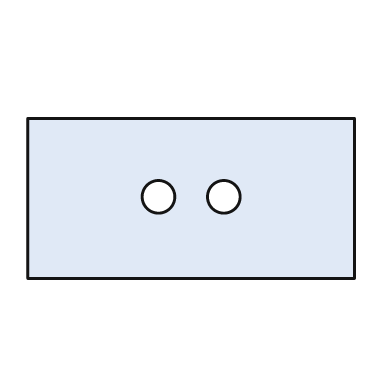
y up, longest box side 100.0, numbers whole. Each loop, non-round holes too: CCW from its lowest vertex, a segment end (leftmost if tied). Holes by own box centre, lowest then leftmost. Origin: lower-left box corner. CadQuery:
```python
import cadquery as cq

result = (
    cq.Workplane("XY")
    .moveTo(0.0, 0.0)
    .lineTo(100.0, 0.0)
    .lineTo(100.0, 49.0)
    .lineTo(0.0, 49.0)
    .close()
    .moveTo(40.0, 25.0)
    .circle(5.0)
    .moveTo(60.0, 25.0)
    .circle(5.0)
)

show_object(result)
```